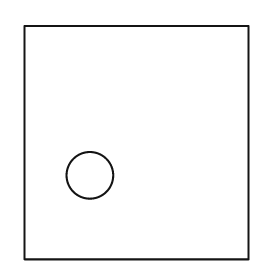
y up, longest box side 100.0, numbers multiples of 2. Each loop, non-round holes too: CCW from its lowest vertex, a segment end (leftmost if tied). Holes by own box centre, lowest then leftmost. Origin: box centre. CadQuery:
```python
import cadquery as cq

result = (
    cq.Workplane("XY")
    .moveTo(-48.0, -50.0)
    .lineTo(48.0, -50.0)
    .lineTo(48.0, 50.0)
    .lineTo(-48.0, 50.0)
    .close()
    .moveTo(-20.0, -14.0)
    .circle(10.0)
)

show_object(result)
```